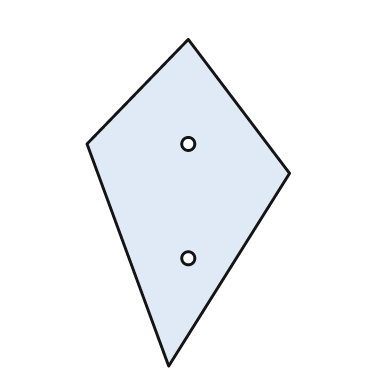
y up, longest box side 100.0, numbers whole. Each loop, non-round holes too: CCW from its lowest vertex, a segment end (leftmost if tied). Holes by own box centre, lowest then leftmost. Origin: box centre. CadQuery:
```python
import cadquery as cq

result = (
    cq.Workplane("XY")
    .moveTo(-6.0, -50.0)
    .lineTo(31.0, 9.0)
    .lineTo(0.0, 50.0)
    .lineTo(-31.0, 18.0)
    .close()
    .moveTo(0.0, -17.0)
    .circle(2.0)
    .moveTo(0.0, 18.0)
    .circle(2.0)
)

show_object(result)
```